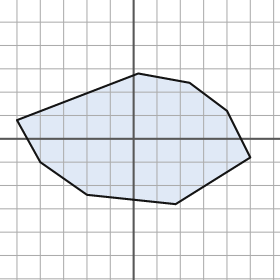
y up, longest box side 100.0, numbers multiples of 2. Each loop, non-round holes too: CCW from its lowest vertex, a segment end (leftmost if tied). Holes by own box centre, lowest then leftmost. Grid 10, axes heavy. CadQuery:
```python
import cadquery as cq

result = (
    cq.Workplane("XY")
    .moveTo(18.0, -28.0)
    .lineTo(50.0, -8.0)
    .lineTo(40.0, 12.0)
    .lineTo(24.0, 24.0)
    .lineTo(2.0, 28.0)
    .lineTo(-50.0, 8.0)
    .lineTo(-40.0, -10.0)
    .lineTo(-20.0, -24.0)
    .close()
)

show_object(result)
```